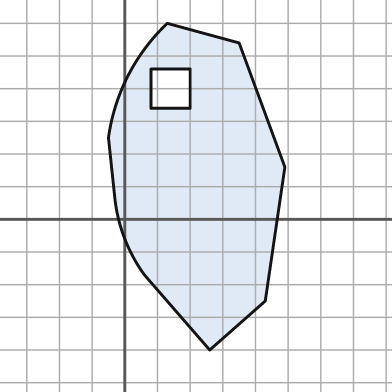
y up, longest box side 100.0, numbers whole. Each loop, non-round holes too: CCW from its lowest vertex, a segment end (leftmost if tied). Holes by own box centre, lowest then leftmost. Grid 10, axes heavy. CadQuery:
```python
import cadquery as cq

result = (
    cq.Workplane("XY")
    .moveTo(26.0, -40.0)
    .lineTo(43.0, -25.0)
    .lineTo(49.0, 16.0)
    .lineTo(35.0, 54.0)
    .lineTo(13.0, 60.0)
    .threePointArc((1.0, 44.0), (-5.0, 25.0))
    .lineTo(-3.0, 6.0)
    .threePointArc((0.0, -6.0), (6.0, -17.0))
    .close()
    .moveTo(8.0, 34.0)
    .lineTo(20.0, 34.0)
    .lineTo(20.0, 46.0)
    .lineTo(8.0, 46.0)
    .close()
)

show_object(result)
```